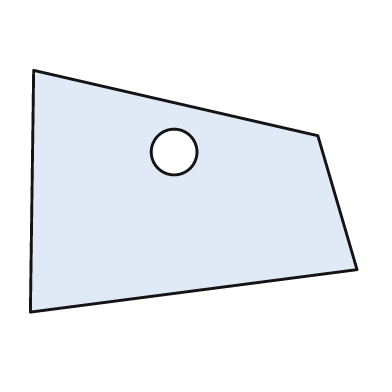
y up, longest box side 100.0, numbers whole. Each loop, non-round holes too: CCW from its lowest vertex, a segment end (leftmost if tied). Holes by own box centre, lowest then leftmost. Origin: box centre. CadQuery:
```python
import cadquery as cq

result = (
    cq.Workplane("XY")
    .moveTo(-50.0, -37.0)
    .lineTo(50.0, -24.0)
    .lineTo(38.0, 17.0)
    .lineTo(-49.0, 37.0)
    .close()
    .moveTo(-6.0, 12.0)
    .circle(7.0)
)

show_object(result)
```